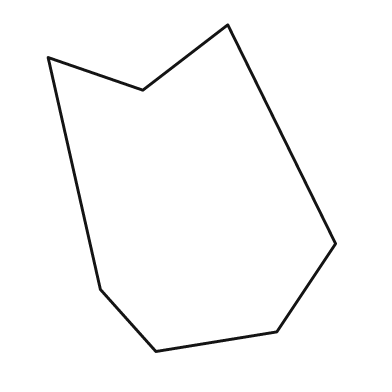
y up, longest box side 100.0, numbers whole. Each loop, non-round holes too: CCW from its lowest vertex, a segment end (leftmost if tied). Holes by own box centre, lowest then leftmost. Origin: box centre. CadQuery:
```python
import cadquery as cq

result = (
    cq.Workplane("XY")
    .moveTo(-11.0, -50.0)
    .lineTo(26.0, -44.0)
    .lineTo(44.0, -17.0)
    .lineTo(11.0, 50.0)
    .lineTo(-15.0, 30.0)
    .lineTo(-44.0, 40.0)
    .lineTo(-28.0, -31.0)
    .close()
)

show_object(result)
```